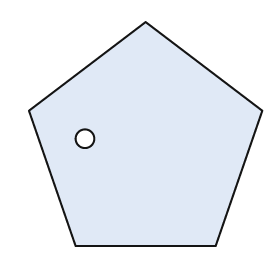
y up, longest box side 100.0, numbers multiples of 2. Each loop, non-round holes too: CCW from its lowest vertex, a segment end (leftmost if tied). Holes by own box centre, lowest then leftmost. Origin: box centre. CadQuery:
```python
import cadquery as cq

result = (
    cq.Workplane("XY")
    .moveTo(-30.0, -48.0)
    .lineTo(30.0, -48.0)
    .lineTo(50.0, 10.0)
    .lineTo(0.0, 48.0)
    .lineTo(-50.0, 10.0)
    .close()
    .moveTo(-26.0, -2.0)
    .circle(4.0)
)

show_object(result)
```